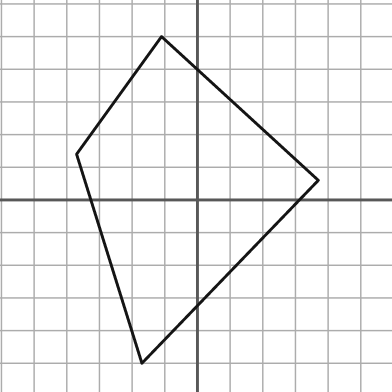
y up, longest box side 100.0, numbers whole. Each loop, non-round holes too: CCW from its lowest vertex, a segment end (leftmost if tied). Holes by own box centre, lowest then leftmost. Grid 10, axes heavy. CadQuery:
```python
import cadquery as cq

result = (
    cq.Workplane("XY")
    .moveTo(-17.0, -50.0)
    .lineTo(37.0, 6.0)
    .lineTo(-11.0, 50.0)
    .lineTo(-37.0, 14.0)
    .close()
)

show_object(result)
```